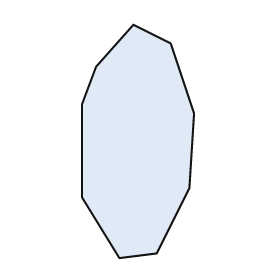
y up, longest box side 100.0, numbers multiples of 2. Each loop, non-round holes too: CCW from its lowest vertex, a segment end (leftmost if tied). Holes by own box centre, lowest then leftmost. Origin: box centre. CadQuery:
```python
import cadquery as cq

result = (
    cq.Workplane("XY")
    .moveTo(-8.0, -50.0)
    .lineTo(8.0, -48.0)
    .lineTo(22.0, -20.0)
    .lineTo(24.0, 12.0)
    .lineTo(14.0, 42.0)
    .lineTo(-2.0, 50.0)
    .lineTo(-18.0, 32.0)
    .lineTo(-24.0, 16.0)
    .lineTo(-24.0, -24.0)
    .close()
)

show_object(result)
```